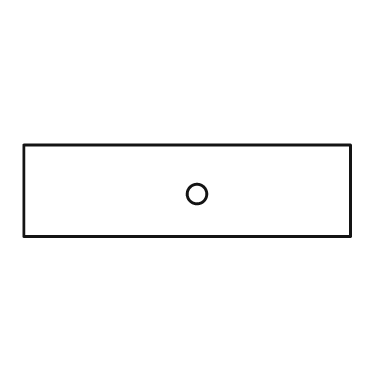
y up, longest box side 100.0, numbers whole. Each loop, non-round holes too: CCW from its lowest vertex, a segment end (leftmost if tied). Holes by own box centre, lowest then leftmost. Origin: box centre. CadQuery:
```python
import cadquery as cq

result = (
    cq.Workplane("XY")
    .moveTo(-50.0, -14.0)
    .lineTo(50.0, -14.0)
    .lineTo(50.0, 14.0)
    .lineTo(-50.0, 14.0)
    .close()
    .moveTo(3.0, -1.0)
    .circle(3.0)
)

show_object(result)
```